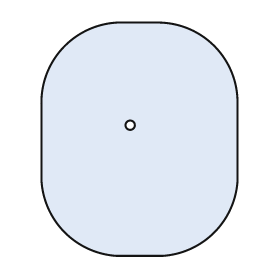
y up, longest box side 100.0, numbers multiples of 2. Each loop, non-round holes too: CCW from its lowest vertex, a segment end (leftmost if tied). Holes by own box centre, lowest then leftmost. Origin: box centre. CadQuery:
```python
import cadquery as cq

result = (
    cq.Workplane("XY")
    .moveTo(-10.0, -50.0)
    .lineTo(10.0, -50.0)
    .threePointArc((32.0, -40.0), (42.0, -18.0))
    .lineTo(42.0, 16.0)
    .threePointArc((32.0, 40.0), (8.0, 50.0))
    .lineTo(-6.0, 50.0)
    .threePointArc((-32.0, 40.0), (-42.0, 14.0))
    .lineTo(-42.0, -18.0)
    .threePointArc((-32.0, -40.0), (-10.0, -50.0))
    .close()
    .moveTo(-4.0, 6.0)
    .circle(2.0)
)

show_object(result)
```